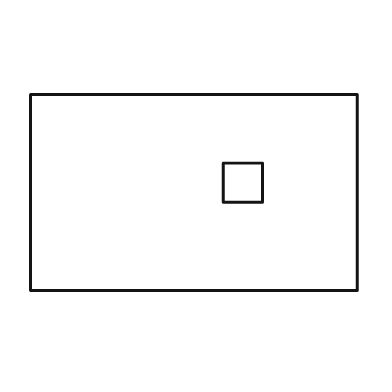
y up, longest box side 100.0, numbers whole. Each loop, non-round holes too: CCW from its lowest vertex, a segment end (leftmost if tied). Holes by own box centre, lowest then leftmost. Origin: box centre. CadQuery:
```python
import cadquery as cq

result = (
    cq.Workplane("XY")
    .moveTo(-50.0, -30.0)
    .lineTo(50.0, -30.0)
    .lineTo(50.0, 30.0)
    .lineTo(-50.0, 30.0)
    .close()
    .moveTo(9.0, -3.0)
    .lineTo(21.0, -3.0)
    .lineTo(21.0, 9.0)
    .lineTo(9.0, 9.0)
    .close()
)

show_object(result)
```